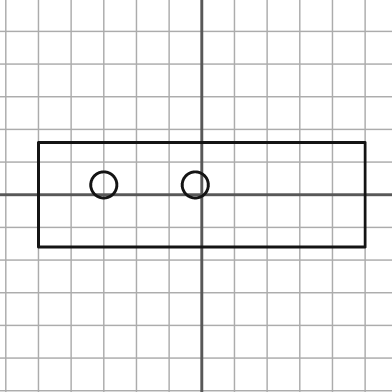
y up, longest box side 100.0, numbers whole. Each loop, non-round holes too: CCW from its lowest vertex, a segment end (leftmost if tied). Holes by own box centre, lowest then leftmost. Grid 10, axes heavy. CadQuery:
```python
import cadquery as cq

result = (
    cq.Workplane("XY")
    .moveTo(-50.0, -16.0)
    .lineTo(50.0, -16.0)
    .lineTo(50.0, 16.0)
    .lineTo(-50.0, 16.0)
    .close()
    .moveTo(-30.0, 3.0)
    .circle(4.0)
    .moveTo(-2.0, 3.0)
    .circle(4.0)
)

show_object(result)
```